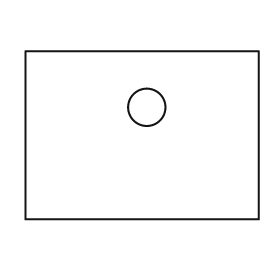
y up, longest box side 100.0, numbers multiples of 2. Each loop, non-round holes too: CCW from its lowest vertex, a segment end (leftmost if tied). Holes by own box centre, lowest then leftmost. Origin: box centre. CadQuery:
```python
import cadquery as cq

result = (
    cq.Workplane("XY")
    .moveTo(-50.0, -36.0)
    .lineTo(50.0, -36.0)
    .lineTo(50.0, 36.0)
    .lineTo(-50.0, 36.0)
    .close()
    .moveTo(2.0, 12.0)
    .circle(8.0)
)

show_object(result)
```